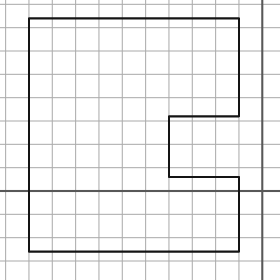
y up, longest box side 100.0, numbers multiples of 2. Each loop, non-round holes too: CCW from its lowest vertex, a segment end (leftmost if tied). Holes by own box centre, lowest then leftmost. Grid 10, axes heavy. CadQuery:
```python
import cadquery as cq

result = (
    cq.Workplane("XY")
    .moveTo(-100.0, -26.0)
    .lineTo(-10.0, -26.0)
    .lineTo(-10.0, 6.0)
    .lineTo(-40.0, 6.0)
    .lineTo(-40.0, 32.0)
    .lineTo(-10.0, 32.0)
    .lineTo(-10.0, 74.0)
    .lineTo(-100.0, 74.0)
    .close()
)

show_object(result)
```